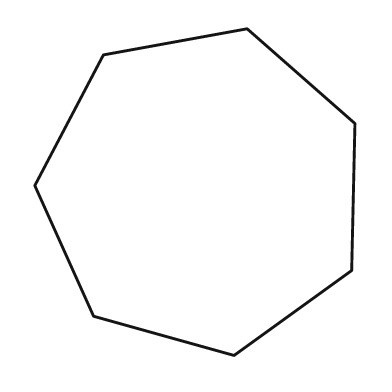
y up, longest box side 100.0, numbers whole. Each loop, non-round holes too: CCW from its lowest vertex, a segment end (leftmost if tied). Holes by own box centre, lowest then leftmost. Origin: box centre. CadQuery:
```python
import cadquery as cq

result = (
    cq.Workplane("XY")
    .moveTo(12.0, -50.0)
    .lineTo(48.0, -24.0)
    .lineTo(49.0, 21.0)
    .lineTo(16.0, 50.0)
    .lineTo(-28.0, 42.0)
    .lineTo(-49.0, 2.0)
    .lineTo(-31.0, -38.0)
    .close()
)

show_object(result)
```